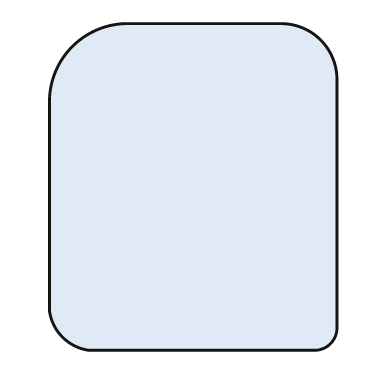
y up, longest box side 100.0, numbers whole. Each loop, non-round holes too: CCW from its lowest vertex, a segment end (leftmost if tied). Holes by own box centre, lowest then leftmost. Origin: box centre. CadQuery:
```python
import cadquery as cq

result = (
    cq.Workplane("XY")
    .moveTo(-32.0, -50.0)
    .lineTo(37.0, -50.0)
    .threePointArc((42.0, -48.0), (44.0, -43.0))
    .lineTo(44.0, 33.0)
    .threePointArc((39.0, 45.0), (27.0, 50.0))
    .lineTo(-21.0, 50.0)
    .threePointArc((-37.0, 43.0), (-44.0, 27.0))
    .lineTo(-44.0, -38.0)
    .threePointArc((-40.0, -46.0), (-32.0, -50.0))
    .close()
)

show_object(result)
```